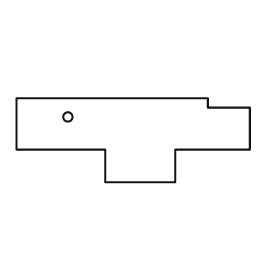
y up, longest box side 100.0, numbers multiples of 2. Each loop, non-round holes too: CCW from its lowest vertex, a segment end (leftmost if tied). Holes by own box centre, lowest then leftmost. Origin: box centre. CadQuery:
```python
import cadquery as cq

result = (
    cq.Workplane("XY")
    .moveTo(-12.0, -18.0)
    .lineTo(18.0, -18.0)
    .lineTo(18.0, -4.0)
    .lineTo(50.0, -4.0)
    .lineTo(50.0, 14.0)
    .lineTo(32.0, 14.0)
    .lineTo(32.0, 18.0)
    .lineTo(-50.0, 18.0)
    .lineTo(-50.0, -4.0)
    .lineTo(-12.0, -4.0)
    .close()
    .moveTo(-28.0, 10.0)
    .circle(2.0)
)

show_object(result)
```